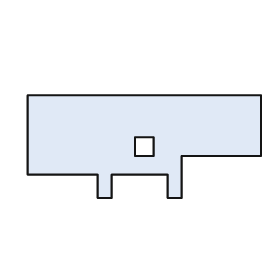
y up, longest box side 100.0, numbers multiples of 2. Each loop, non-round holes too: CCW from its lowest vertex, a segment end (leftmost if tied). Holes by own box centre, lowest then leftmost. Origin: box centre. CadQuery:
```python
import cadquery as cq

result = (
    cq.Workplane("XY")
    .moveTo(-20.0, -22.0)
    .lineTo(-14.0, -22.0)
    .lineTo(-14.0, -12.0)
    .lineTo(10.0, -12.0)
    .lineTo(10.0, -22.0)
    .lineTo(16.0, -22.0)
    .lineTo(16.0, -4.0)
    .lineTo(50.0, -4.0)
    .lineTo(50.0, 22.0)
    .lineTo(-50.0, 22.0)
    .lineTo(-50.0, -12.0)
    .lineTo(-20.0, -12.0)
    .close()
    .moveTo(-4.0, -4.0)
    .lineTo(4.0, -4.0)
    .lineTo(4.0, 4.0)
    .lineTo(-4.0, 4.0)
    .close()
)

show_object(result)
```